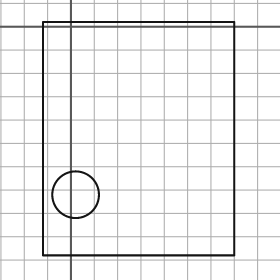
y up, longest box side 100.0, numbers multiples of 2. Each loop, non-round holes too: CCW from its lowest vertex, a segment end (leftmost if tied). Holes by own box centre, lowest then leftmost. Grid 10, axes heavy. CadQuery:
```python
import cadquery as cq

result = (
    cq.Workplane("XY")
    .moveTo(-12.0, -98.0)
    .lineTo(70.0, -98.0)
    .lineTo(70.0, 2.0)
    .lineTo(-12.0, 2.0)
    .close()
    .moveTo(2.0, -72.0)
    .circle(10.0)
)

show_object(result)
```